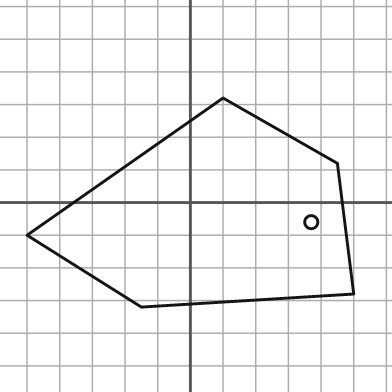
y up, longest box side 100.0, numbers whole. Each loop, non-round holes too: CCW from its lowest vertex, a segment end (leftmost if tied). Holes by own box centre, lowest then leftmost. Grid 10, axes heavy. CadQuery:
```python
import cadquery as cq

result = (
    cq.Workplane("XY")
    .moveTo(-15.0, -32.0)
    .lineTo(50.0, -28.0)
    .lineTo(45.0, 12.0)
    .lineTo(10.0, 32.0)
    .lineTo(-50.0, -10.0)
    .close()
    .moveTo(37.0, -6.0)
    .circle(2.0)
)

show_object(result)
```